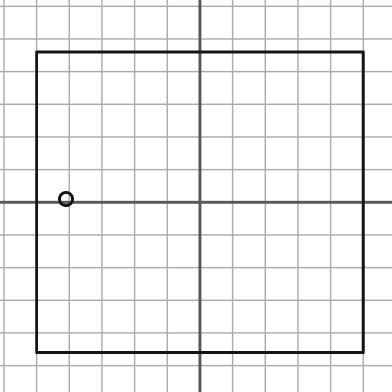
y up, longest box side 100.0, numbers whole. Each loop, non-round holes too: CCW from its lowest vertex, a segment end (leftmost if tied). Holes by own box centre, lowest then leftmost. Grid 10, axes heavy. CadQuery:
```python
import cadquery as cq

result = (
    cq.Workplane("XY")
    .moveTo(-50.0, -46.0)
    .lineTo(50.0, -46.0)
    .lineTo(50.0, 46.0)
    .lineTo(-50.0, 46.0)
    .close()
    .moveTo(-41.0, 1.0)
    .circle(2.0)
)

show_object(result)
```